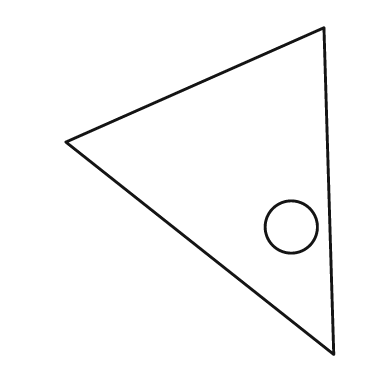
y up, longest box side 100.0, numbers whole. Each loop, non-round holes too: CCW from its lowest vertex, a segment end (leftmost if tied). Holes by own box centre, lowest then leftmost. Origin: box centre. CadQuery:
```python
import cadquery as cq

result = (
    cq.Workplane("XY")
    .moveTo(41.0, -50.0)
    .lineTo(38.0, 50.0)
    .lineTo(-41.0, 15.0)
    .close()
    .moveTo(28.0, -11.0)
    .circle(8.0)
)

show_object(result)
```